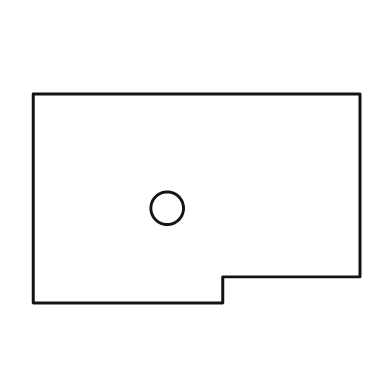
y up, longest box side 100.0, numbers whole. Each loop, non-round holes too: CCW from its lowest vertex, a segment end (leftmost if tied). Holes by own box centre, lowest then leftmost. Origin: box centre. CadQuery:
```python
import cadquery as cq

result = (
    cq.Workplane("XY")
    .moveTo(-50.0, -32.0)
    .lineTo(8.0, -32.0)
    .lineTo(8.0, -24.0)
    .lineTo(50.0, -24.0)
    .lineTo(50.0, 32.0)
    .lineTo(-50.0, 32.0)
    .close()
    .moveTo(-9.0, -3.0)
    .circle(5.0)
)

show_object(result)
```